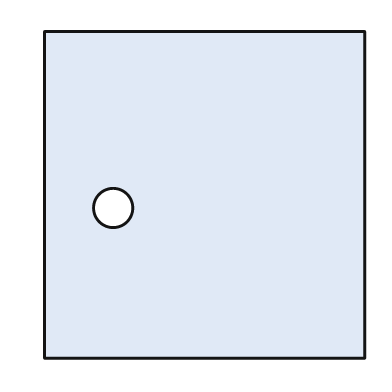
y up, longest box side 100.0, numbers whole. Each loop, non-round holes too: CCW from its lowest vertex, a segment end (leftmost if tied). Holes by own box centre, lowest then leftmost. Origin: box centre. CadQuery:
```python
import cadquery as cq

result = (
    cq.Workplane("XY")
    .moveTo(-49.0, -50.0)
    .lineTo(49.0, -50.0)
    .lineTo(49.0, 50.0)
    .lineTo(-49.0, 50.0)
    .close()
    .moveTo(-28.0, -4.0)
    .circle(6.0)
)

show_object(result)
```